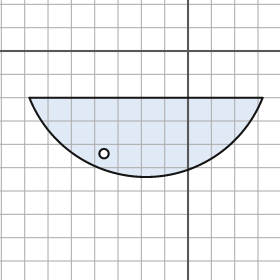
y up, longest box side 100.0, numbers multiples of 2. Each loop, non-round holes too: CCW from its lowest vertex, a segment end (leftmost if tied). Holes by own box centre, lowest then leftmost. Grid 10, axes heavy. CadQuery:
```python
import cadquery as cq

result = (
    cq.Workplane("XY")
    .moveTo(-68.0, -20.0)
    .threePointArc((-18.0, -54.0), (32.0, -20.0))
    .close()
    .moveTo(-36.0, -44.0)
    .circle(2.0)
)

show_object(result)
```